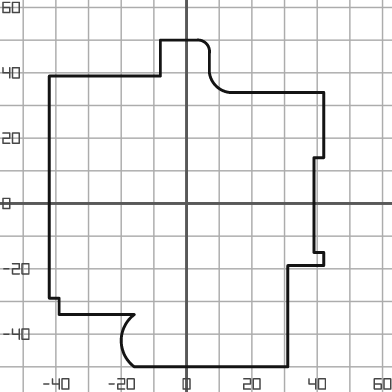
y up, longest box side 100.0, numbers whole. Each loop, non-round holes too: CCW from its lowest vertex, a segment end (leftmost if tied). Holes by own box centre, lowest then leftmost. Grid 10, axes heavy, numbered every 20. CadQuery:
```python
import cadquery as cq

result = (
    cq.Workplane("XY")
    .moveTo(-16.0, -50.0)
    .lineTo(31.0, -50.0)
    .lineTo(31.0, -19.0)
    .lineTo(42.0, -19.0)
    .lineTo(42.0, -15.0)
    .lineTo(39.0, -15.0)
    .lineTo(39.0, 14.0)
    .lineTo(42.0, 14.0)
    .lineTo(42.0, 34.0)
    .lineTo(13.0, 34.0)
    .threePointArc((9.0, 36.0), (7.0, 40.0))
    .lineTo(7.0, 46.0)
    .threePointArc((6.0, 49.0), (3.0, 50.0))
    .lineTo(-8.0, 50.0)
    .lineTo(-8.0, 39.0)
    .lineTo(-42.0, 39.0)
    .lineTo(-42.0, -29.0)
    .lineTo(-39.0, -29.0)
    .lineTo(-39.0, -34.0)
    .lineTo(-16.0, -34.0)
    .threePointArc((-20.0, -42.0), (-16.0, -50.0))
    .close()
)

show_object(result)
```